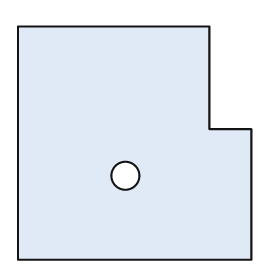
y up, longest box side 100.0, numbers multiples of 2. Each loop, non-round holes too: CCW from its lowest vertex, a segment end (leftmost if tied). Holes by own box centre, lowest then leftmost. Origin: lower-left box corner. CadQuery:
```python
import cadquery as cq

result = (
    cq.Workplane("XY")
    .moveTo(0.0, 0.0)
    .lineTo(100.0, 0.0)
    .lineTo(100.0, 56.0)
    .lineTo(82.0, 56.0)
    .lineTo(82.0, 100.0)
    .lineTo(0.0, 100.0)
    .close()
    .moveTo(46.0, 36.0)
    .circle(6.0)
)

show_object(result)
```